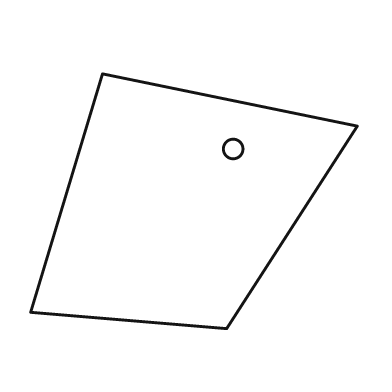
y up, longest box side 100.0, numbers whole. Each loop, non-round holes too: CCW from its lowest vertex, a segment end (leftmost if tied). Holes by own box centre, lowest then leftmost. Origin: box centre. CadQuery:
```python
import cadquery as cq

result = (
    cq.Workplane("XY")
    .moveTo(10.0, -39.0)
    .lineTo(50.0, 23.0)
    .lineTo(-28.0, 39.0)
    .lineTo(-50.0, -34.0)
    .close()
    .moveTo(12.0, 16.0)
    .circle(3.0)
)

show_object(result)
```